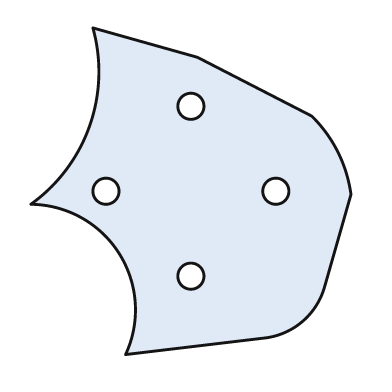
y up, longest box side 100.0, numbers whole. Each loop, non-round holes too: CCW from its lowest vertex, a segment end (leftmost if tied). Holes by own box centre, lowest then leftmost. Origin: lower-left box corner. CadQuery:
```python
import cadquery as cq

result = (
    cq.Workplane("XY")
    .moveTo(29.0, 0.0)
    .lineTo(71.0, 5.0)
    .threePointArc((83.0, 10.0), (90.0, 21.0))
    .lineTo(98.0, 49.0)
    .threePointArc((94.0, 62.0), (86.0, 73.0))
    .lineTo(51.0, 91.0)
    .lineTo(19.0, 100.0)
    .threePointArc((18.0, 70.0), (0.0, 46.0))
    .threePointArc((27.0, 31.0), (29.0, 0.0))
    .close()
    .moveTo(49.0, 24.0)
    .circle(4.0)
    .moveTo(23.0, 50.0)
    .circle(4.0)
    .moveTo(75.0, 50.0)
    .circle(4.0)
    .moveTo(49.0, 76.0)
    .circle(4.0)
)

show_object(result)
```